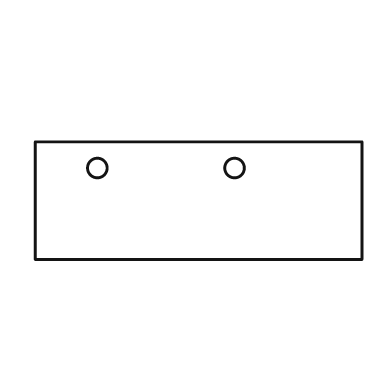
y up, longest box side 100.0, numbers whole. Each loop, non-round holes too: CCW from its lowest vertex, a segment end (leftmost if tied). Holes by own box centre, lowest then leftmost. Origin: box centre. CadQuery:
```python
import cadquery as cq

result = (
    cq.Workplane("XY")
    .moveTo(-50.0, -18.0)
    .lineTo(50.0, -18.0)
    .lineTo(50.0, 18.0)
    .lineTo(-50.0, 18.0)
    .close()
    .moveTo(-31.0, 10.0)
    .circle(3.0)
    .moveTo(11.0, 10.0)
    .circle(3.0)
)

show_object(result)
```